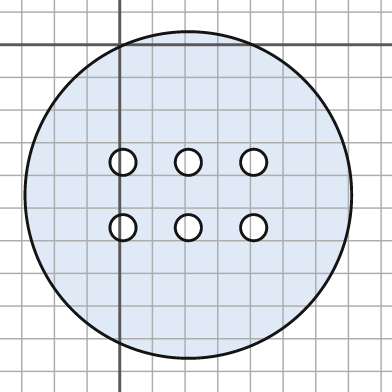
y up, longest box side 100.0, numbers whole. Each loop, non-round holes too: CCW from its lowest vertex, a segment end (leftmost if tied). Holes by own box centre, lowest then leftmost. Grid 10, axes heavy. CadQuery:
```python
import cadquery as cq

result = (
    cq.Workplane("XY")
    .moveTo(21.0, -46.0)
    .circle(50.0)
    .moveTo(1.0, -56.0)
    .circle(4.0)
    .moveTo(21.0, -56.0)
    .circle(4.0)
    .moveTo(41.0, -56.0)
    .circle(4.0)
    .moveTo(1.0, -36.0)
    .circle(4.0)
    .moveTo(21.0, -36.0)
    .circle(4.0)
    .moveTo(41.0, -36.0)
    .circle(4.0)
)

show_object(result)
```